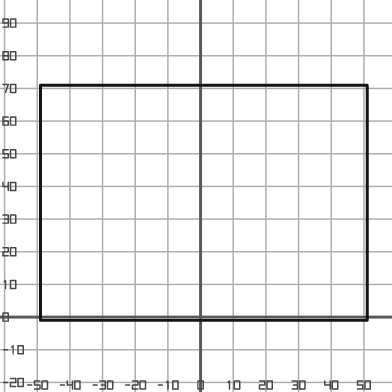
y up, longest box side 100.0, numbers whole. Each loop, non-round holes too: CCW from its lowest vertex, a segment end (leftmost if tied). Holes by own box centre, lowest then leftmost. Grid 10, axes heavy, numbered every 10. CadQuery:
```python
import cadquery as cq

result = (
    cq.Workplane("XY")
    .moveTo(-49.0, -1.0)
    .lineTo(51.0, -1.0)
    .lineTo(51.0, 71.0)
    .lineTo(-49.0, 71.0)
    .close()
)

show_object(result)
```